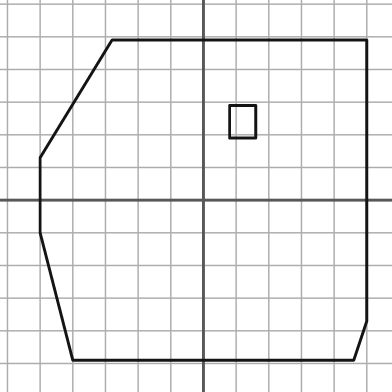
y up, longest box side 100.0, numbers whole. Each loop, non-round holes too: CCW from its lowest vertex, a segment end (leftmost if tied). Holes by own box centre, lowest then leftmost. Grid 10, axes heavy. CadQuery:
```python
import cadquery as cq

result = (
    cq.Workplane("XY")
    .moveTo(-40.0, -49.0)
    .lineTo(46.0, -49.0)
    .lineTo(50.0, -37.0)
    .lineTo(50.0, 49.0)
    .lineTo(-28.0, 49.0)
    .lineTo(-50.0, 13.0)
    .lineTo(-50.0, -10.0)
    .close()
    .moveTo(8.0, 19.0)
    .lineTo(16.0, 19.0)
    .lineTo(16.0, 29.0)
    .lineTo(8.0, 29.0)
    .close()
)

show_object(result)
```